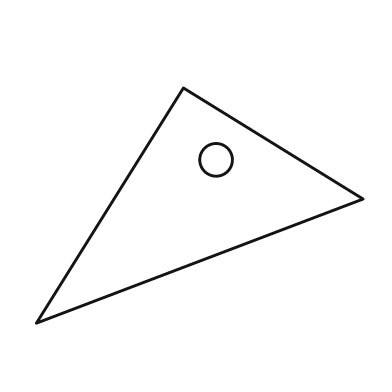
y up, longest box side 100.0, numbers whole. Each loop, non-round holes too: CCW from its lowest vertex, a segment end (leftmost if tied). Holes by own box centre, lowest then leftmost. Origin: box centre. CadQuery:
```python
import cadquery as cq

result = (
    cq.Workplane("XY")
    .moveTo(-50.0, -36.0)
    .lineTo(50.0, 2.0)
    .lineTo(-5.0, 36.0)
    .close()
    .moveTo(5.0, 14.0)
    .circle(5.0)
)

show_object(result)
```